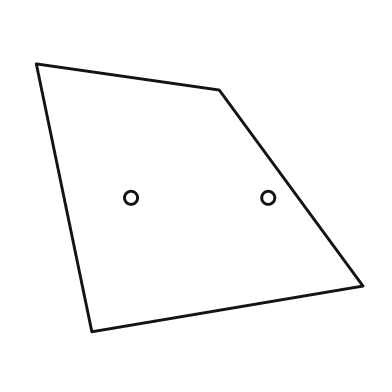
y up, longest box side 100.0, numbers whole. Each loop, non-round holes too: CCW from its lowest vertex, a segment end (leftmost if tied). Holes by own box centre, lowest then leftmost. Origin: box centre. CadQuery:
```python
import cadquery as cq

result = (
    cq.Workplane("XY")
    .moveTo(-33.0, -41.0)
    .lineTo(50.0, -27.0)
    .lineTo(6.0, 33.0)
    .lineTo(-50.0, 41.0)
    .close()
    .moveTo(-21.0, 0.0)
    .circle(2.0)
    .moveTo(21.0, 0.0)
    .circle(2.0)
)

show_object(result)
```